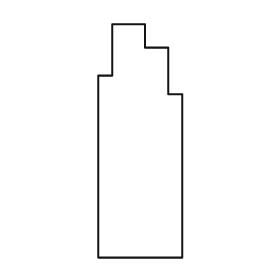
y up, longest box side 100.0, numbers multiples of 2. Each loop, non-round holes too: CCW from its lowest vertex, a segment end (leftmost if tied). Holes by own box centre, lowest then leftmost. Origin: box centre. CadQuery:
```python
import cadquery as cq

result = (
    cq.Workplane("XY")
    .moveTo(-18.0, -50.0)
    .lineTo(18.0, -50.0)
    .lineTo(18.0, 20.0)
    .lineTo(12.0, 20.0)
    .lineTo(12.0, 40.0)
    .lineTo(2.0, 40.0)
    .lineTo(2.0, 50.0)
    .lineTo(-12.0, 50.0)
    .lineTo(-12.0, 28.0)
    .lineTo(-18.0, 28.0)
    .close()
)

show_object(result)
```